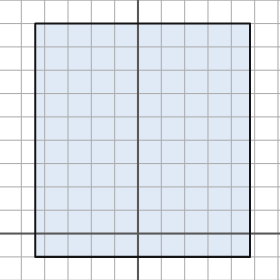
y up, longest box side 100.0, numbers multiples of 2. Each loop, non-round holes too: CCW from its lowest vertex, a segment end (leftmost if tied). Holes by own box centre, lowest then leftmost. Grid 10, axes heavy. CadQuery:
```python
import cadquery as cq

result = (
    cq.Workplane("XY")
    .moveTo(-44.0, -10.0)
    .lineTo(48.0, -10.0)
    .lineTo(48.0, 90.0)
    .lineTo(-44.0, 90.0)
    .close()
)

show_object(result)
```